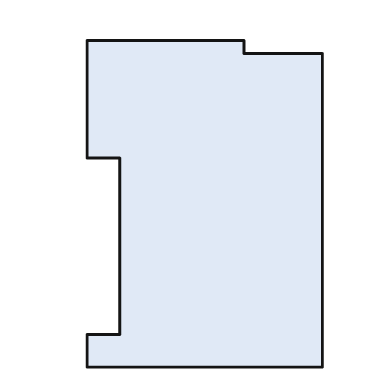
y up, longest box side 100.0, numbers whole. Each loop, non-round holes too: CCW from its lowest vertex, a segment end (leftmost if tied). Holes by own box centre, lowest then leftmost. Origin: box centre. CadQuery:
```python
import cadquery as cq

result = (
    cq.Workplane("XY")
    .moveTo(-36.0, -50.0)
    .lineTo(36.0, -50.0)
    .lineTo(36.0, 46.0)
    .lineTo(12.0, 46.0)
    .lineTo(12.0, 50.0)
    .lineTo(-36.0, 50.0)
    .lineTo(-36.0, 14.0)
    .lineTo(-26.0, 14.0)
    .lineTo(-26.0, -40.0)
    .lineTo(-36.0, -40.0)
    .close()
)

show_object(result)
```